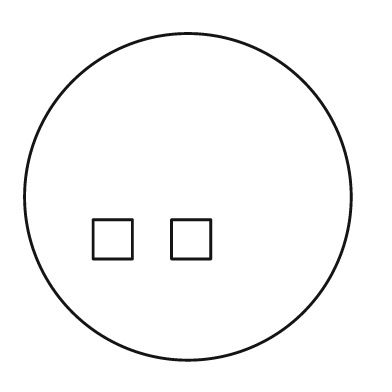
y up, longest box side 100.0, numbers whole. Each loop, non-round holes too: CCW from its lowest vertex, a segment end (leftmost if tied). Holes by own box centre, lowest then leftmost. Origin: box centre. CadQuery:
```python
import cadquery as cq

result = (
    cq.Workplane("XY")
    .moveTo(0.0, 0.0)
    .circle(50.0)
    .moveTo(-29.0, -19.0)
    .lineTo(-17.0, -19.0)
    .lineTo(-17.0, -7.0)
    .lineTo(-29.0, -7.0)
    .close()
    .moveTo(-5.0, -19.0)
    .lineTo(7.0, -19.0)
    .lineTo(7.0, -7.0)
    .lineTo(-5.0, -7.0)
    .close()
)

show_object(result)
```